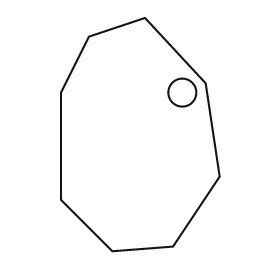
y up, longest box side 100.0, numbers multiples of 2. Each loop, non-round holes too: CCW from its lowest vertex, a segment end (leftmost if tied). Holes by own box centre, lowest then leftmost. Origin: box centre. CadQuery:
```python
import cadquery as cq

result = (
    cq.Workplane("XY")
    .moveTo(-12.0, -50.0)
    .lineTo(14.0, -48.0)
    .lineTo(34.0, -18.0)
    .lineTo(28.0, 22.0)
    .lineTo(2.0, 50.0)
    .lineTo(-22.0, 42.0)
    .lineTo(-34.0, 18.0)
    .lineTo(-34.0, -28.0)
    .close()
    .moveTo(18.0, 18.0)
    .circle(6.0)
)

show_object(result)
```